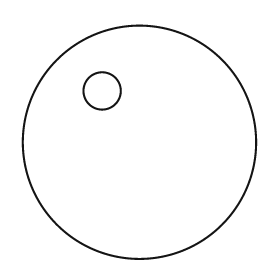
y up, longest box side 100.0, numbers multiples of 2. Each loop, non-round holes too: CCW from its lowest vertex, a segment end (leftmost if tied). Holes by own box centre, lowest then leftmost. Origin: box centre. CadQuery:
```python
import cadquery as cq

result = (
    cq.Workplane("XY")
    .moveTo(0.0, 0.0)
    .circle(50.0)
    .moveTo(-16.0, 22.0)
    .circle(8.0)
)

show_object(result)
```